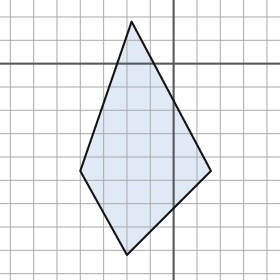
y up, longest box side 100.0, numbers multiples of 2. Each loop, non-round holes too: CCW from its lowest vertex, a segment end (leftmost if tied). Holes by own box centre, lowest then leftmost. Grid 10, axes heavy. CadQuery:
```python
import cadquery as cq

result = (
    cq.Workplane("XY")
    .moveTo(-20.0, -82.0)
    .lineTo(16.0, -46.0)
    .lineTo(-18.0, 18.0)
    .lineTo(-40.0, -46.0)
    .close()
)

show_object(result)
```